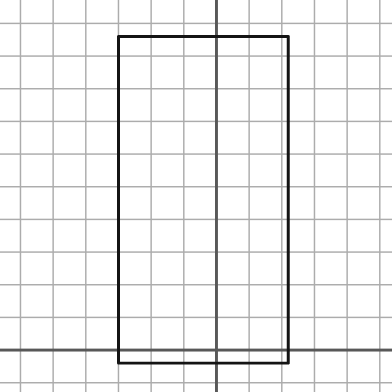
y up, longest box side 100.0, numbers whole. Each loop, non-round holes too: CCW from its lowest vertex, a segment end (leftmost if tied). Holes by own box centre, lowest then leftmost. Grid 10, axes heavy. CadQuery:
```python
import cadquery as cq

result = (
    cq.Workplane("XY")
    .moveTo(-30.0, -4.0)
    .lineTo(22.0, -4.0)
    .lineTo(22.0, 96.0)
    .lineTo(-30.0, 96.0)
    .close()
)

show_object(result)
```